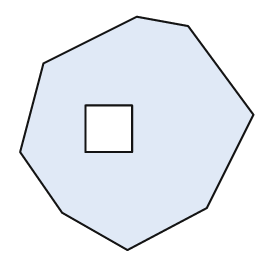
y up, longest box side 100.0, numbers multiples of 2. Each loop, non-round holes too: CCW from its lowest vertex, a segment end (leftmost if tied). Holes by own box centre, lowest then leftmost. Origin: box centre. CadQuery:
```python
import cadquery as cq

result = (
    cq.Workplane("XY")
    .moveTo(-4.0, -50.0)
    .lineTo(30.0, -32.0)
    .lineTo(50.0, 8.0)
    .lineTo(22.0, 46.0)
    .lineTo(0.0, 50.0)
    .lineTo(-40.0, 30.0)
    .lineTo(-50.0, -8.0)
    .lineTo(-32.0, -34.0)
    .close()
    .moveTo(-22.0, -8.0)
    .lineTo(-2.0, -8.0)
    .lineTo(-2.0, 12.0)
    .lineTo(-22.0, 12.0)
    .close()
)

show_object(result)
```